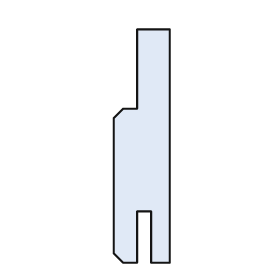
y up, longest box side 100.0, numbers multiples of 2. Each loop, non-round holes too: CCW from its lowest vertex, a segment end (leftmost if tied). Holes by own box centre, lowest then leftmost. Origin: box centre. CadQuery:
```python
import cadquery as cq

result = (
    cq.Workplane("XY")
    .moveTo(-8.0, -50.0)
    .lineTo(-2.0, -50.0)
    .lineTo(-2.0, -28.0)
    .lineTo(4.0, -28.0)
    .lineTo(4.0, -50.0)
    .lineTo(12.0, -50.0)
    .lineTo(12.0, 50.0)
    .lineTo(-2.0, 50.0)
    .lineTo(-2.0, 16.0)
    .lineTo(-8.0, 16.0)
    .lineTo(-12.0, 12.0)
    .lineTo(-12.0, -46.0)
    .close()
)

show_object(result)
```